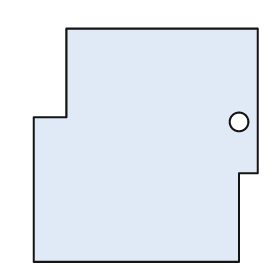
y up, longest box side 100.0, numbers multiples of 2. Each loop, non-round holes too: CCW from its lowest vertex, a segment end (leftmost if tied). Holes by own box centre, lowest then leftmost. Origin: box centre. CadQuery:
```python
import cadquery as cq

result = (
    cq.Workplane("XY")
    .moveTo(-48.0, -50.0)
    .lineTo(40.0, -50.0)
    .lineTo(40.0, -12.0)
    .lineTo(48.0, -12.0)
    .lineTo(48.0, 50.0)
    .lineTo(-34.0, 50.0)
    .lineTo(-34.0, 12.0)
    .lineTo(-48.0, 12.0)
    .close()
    .moveTo(40.0, 10.0)
    .circle(4.0)
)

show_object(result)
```